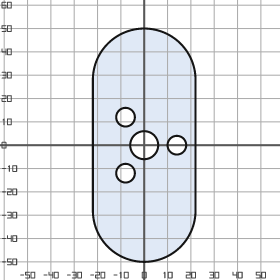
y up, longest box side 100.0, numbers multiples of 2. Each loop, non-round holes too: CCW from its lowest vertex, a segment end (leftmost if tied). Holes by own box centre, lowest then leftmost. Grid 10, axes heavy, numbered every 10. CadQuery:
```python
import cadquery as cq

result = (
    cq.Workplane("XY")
    .moveTo(-22.0, -28.0)
    .threePointArc((0.0, -50.0), (22.0, -28.0))
    .lineTo(22.0, 28.0)
    .threePointArc((0.0, 50.0), (-22.0, 28.0))
    .close()
    .moveTo(-8.0, -12.0)
    .circle(4.0)
    .moveTo(0.0, 0.0)
    .circle(6.0)
    .moveTo(14.0, 0.0)
    .circle(4.0)
    .moveTo(-8.0, 12.0)
    .circle(4.0)
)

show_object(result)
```